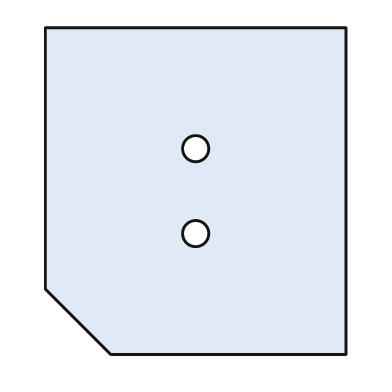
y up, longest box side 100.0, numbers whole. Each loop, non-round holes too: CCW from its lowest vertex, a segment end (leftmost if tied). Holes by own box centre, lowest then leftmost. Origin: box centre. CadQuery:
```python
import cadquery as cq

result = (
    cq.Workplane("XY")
    .moveTo(-26.0, -50.0)
    .lineTo(46.0, -50.0)
    .lineTo(46.0, 50.0)
    .lineTo(-46.0, 50.0)
    .lineTo(-46.0, -30.0)
    .close()
    .moveTo(0.0, -13.0)
    .circle(4.0)
    .moveTo(0.0, 13.0)
    .circle(4.0)
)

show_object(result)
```